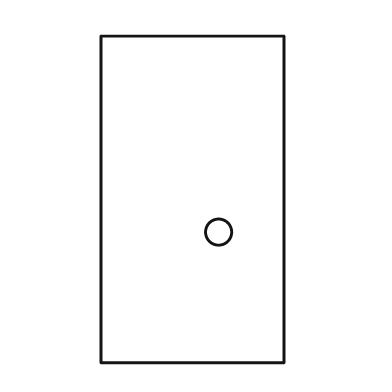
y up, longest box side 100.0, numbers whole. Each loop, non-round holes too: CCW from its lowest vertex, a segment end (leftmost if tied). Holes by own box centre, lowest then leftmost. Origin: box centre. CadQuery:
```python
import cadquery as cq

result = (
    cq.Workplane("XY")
    .moveTo(-28.0, -50.0)
    .lineTo(28.0, -50.0)
    .lineTo(28.0, 50.0)
    .lineTo(-28.0, 50.0)
    .close()
    .moveTo(8.0, -10.0)
    .circle(4.0)
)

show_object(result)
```